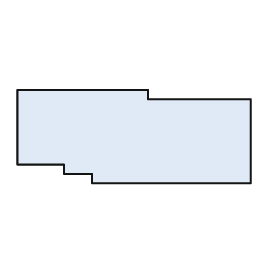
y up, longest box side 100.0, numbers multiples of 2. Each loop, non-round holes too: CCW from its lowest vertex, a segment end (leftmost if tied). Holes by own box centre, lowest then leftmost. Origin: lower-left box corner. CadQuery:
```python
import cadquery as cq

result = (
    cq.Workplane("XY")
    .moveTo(32.0, 0.0)
    .lineTo(100.0, 0.0)
    .lineTo(100.0, 36.0)
    .lineTo(56.0, 36.0)
    .lineTo(56.0, 40.0)
    .lineTo(0.0, 40.0)
    .lineTo(0.0, 8.0)
    .lineTo(20.0, 8.0)
    .lineTo(20.0, 4.0)
    .lineTo(32.0, 4.0)
    .close()
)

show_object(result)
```